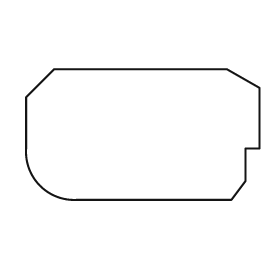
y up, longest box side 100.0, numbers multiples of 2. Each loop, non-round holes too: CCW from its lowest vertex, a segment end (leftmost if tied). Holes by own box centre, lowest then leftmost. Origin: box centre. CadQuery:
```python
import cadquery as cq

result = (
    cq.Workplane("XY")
    .moveTo(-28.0, -28.0)
    .lineTo(38.0, -28.0)
    .lineTo(44.0, -20.0)
    .lineTo(44.0, -6.0)
    .lineTo(50.0, -6.0)
    .lineTo(50.0, 20.0)
    .lineTo(36.0, 28.0)
    .lineTo(-38.0, 28.0)
    .lineTo(-50.0, 16.0)
    .lineTo(-50.0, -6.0)
    .threePointArc((-44.0, -22.0), (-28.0, -28.0))
    .close()
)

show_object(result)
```